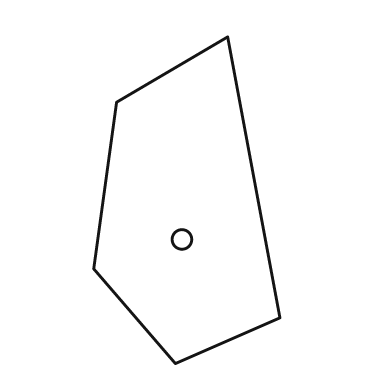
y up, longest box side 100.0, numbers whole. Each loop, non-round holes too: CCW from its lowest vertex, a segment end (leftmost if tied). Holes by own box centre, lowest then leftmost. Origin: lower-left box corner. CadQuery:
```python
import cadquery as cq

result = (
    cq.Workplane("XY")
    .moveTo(25.0, 0.0)
    .lineTo(57.0, 14.0)
    .lineTo(41.0, 100.0)
    .lineTo(7.0, 80.0)
    .lineTo(0.0, 29.0)
    .close()
    .moveTo(27.0, 38.0)
    .circle(3.0)
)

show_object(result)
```